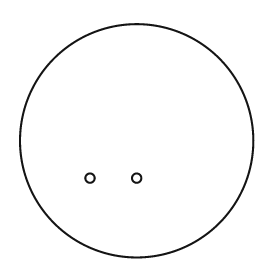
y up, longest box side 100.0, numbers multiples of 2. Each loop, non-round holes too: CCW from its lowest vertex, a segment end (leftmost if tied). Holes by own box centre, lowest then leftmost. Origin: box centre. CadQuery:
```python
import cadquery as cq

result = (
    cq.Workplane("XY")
    .moveTo(0.0, 0.0)
    .circle(50.0)
    .moveTo(-20.0, -16.0)
    .circle(2.0)
    .moveTo(0.0, -16.0)
    .circle(2.0)
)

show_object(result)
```